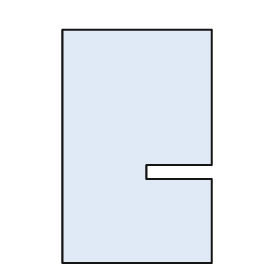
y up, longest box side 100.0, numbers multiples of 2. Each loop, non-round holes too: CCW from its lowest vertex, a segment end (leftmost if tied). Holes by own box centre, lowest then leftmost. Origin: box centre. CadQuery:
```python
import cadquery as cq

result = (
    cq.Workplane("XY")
    .moveTo(-32.0, -50.0)
    .lineTo(32.0, -50.0)
    .lineTo(32.0, -14.0)
    .lineTo(4.0, -14.0)
    .lineTo(4.0, -8.0)
    .lineTo(32.0, -8.0)
    .lineTo(32.0, 50.0)
    .lineTo(-32.0, 50.0)
    .close()
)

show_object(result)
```